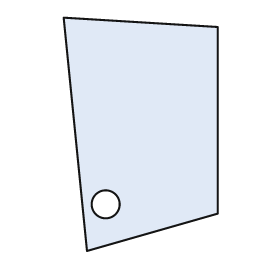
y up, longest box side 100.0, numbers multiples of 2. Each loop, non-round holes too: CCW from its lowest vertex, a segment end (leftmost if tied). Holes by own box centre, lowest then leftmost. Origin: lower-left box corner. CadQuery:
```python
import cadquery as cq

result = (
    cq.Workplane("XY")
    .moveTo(10.0, 0.0)
    .lineTo(66.0, 16.0)
    .lineTo(66.0, 96.0)
    .lineTo(0.0, 100.0)
    .close()
    .moveTo(18.0, 20.0)
    .circle(6.0)
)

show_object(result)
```